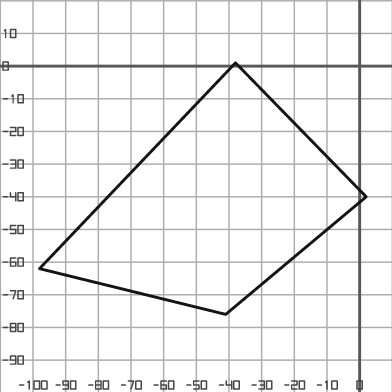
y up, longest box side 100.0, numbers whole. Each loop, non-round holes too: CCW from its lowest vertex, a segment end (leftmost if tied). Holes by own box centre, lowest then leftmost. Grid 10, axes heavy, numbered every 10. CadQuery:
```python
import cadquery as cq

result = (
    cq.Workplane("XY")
    .moveTo(-41.0, -76.0)
    .lineTo(2.0, -40.0)
    .lineTo(-38.0, 1.0)
    .lineTo(-98.0, -62.0)
    .close()
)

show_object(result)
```